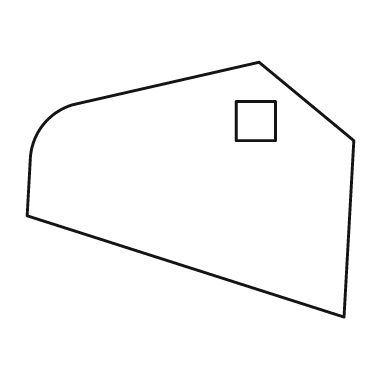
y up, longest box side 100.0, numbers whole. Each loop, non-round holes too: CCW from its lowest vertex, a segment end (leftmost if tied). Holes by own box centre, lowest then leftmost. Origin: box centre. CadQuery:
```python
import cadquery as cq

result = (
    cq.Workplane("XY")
    .moveTo(47.0, -39.0)
    .lineTo(50.0, 15.0)
    .lineTo(21.0, 39.0)
    .lineTo(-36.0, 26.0)
    .threePointArc((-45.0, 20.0), (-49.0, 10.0))
    .lineTo(-50.0, -8.0)
    .close()
    .moveTo(14.0, 15.0)
    .lineTo(26.0, 15.0)
    .lineTo(26.0, 27.0)
    .lineTo(14.0, 27.0)
    .close()
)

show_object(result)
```